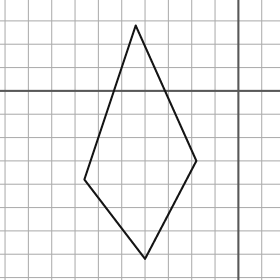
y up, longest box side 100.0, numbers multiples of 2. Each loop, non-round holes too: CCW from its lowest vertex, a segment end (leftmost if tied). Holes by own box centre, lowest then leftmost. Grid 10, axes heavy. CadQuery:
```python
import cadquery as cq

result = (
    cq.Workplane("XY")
    .moveTo(-40.0, -72.0)
    .lineTo(-18.0, -30.0)
    .lineTo(-44.0, 28.0)
    .lineTo(-66.0, -38.0)
    .close()
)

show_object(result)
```